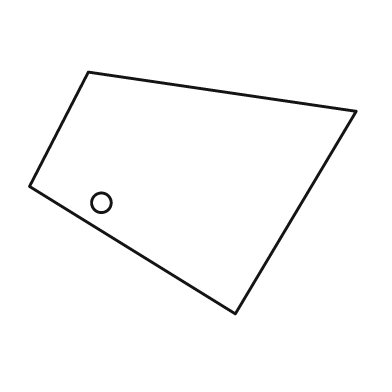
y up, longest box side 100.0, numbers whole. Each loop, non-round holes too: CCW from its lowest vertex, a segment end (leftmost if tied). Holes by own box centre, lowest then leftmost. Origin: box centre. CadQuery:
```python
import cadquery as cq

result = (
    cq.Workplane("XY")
    .moveTo(13.0, -37.0)
    .lineTo(50.0, 25.0)
    .lineTo(-32.0, 37.0)
    .lineTo(-50.0, 2.0)
    .close()
    .moveTo(-28.0, -3.0)
    .circle(3.0)
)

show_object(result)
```